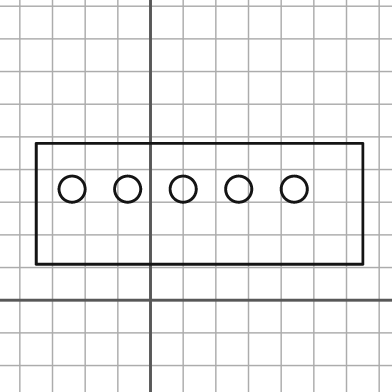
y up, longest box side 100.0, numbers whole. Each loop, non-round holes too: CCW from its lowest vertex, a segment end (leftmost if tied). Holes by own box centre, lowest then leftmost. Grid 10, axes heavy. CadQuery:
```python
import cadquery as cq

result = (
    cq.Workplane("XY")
    .moveTo(-35.0, 11.0)
    .lineTo(65.0, 11.0)
    .lineTo(65.0, 48.0)
    .lineTo(-35.0, 48.0)
    .close()
    .moveTo(-24.0, 34.0)
    .circle(4.0)
    .moveTo(-7.0, 34.0)
    .circle(4.0)
    .moveTo(10.0, 34.0)
    .circle(4.0)
    .moveTo(27.0, 34.0)
    .circle(4.0)
    .moveTo(44.0, 34.0)
    .circle(4.0)
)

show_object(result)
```